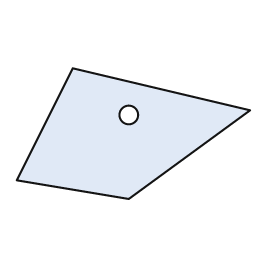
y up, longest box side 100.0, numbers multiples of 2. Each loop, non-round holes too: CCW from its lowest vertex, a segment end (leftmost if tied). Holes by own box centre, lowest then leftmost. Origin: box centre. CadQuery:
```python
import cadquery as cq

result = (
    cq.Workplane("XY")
    .moveTo(-2.0, -28.0)
    .lineTo(50.0, 10.0)
    .lineTo(-26.0, 28.0)
    .lineTo(-50.0, -20.0)
    .close()
    .moveTo(-2.0, 8.0)
    .circle(4.0)
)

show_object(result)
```